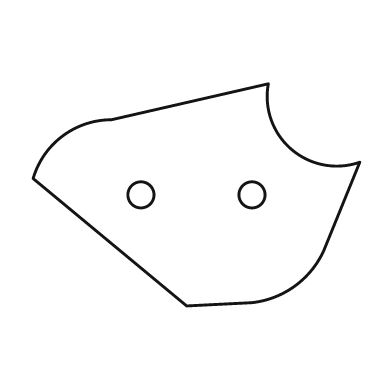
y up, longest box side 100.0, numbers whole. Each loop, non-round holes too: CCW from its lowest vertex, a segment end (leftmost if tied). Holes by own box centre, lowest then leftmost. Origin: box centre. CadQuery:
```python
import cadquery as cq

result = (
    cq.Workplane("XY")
    .moveTo(-3.0, -34.0)
    .lineTo(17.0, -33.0)
    .threePointArc((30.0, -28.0), (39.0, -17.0))
    .lineTo(50.0, 10.0)
    .threePointArc((29.0, 14.0), (22.0, 34.0))
    .lineTo(-26.0, 23.0)
    .threePointArc((-41.0, 18.0), (-50.0, 5.0))
    .close()
    .moveTo(-17.0, 0.0)
    .circle(4.0)
    .moveTo(17.0, 0.0)
    .circle(4.0)
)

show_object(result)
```